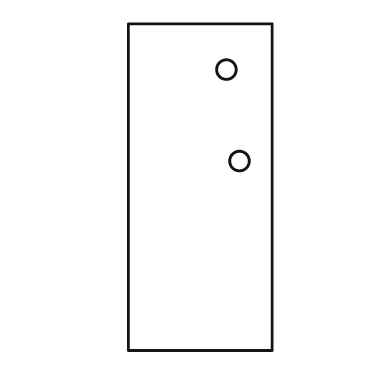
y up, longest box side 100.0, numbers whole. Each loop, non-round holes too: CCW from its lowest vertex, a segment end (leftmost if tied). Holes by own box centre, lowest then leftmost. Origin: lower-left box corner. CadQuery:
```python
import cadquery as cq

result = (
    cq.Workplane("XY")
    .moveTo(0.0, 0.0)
    .lineTo(44.0, 0.0)
    .lineTo(44.0, 100.0)
    .lineTo(0.0, 100.0)
    .close()
    .moveTo(34.0, 58.0)
    .circle(3.0)
    .moveTo(30.0, 86.0)
    .circle(3.0)
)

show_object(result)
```